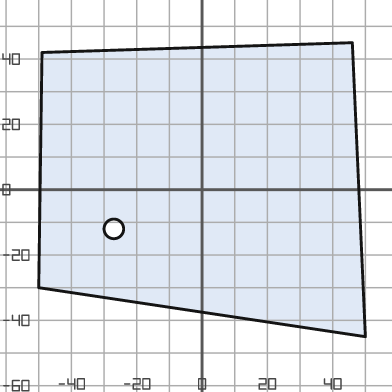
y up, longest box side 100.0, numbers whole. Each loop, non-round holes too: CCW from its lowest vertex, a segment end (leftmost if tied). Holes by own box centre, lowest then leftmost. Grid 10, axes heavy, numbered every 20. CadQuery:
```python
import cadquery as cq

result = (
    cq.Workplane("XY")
    .moveTo(50.0, -45.0)
    .lineTo(46.0, 45.0)
    .lineTo(-49.0, 42.0)
    .lineTo(-50.0, -30.0)
    .close()
    .moveTo(-27.0, -12.0)
    .circle(3.0)
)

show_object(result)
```